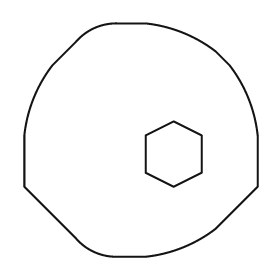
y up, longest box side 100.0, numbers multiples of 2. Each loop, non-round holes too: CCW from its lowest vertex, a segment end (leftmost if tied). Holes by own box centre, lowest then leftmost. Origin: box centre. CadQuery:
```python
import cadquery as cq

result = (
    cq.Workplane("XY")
    .moveTo(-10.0, -50.0)
    .lineTo(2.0, -50.0)
    .threePointArc((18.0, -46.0), (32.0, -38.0))
    .lineTo(50.0, -20.0)
    .lineTo(50.0, 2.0)
    .threePointArc((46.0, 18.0), (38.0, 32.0))
    .lineTo(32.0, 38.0)
    .threePointArc((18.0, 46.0), (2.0, 50.0))
    .lineTo(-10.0, 50.0)
    .threePointArc((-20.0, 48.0), (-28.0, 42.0))
    .lineTo(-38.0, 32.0)
    .threePointArc((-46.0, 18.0), (-50.0, 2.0))
    .lineTo(-50.0, -20.0)
    .lineTo(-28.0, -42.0)
    .threePointArc((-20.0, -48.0), (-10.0, -50.0))
    .close()
    .moveTo(14.0, -20.0)
    .lineTo(26.0, -14.0)
    .lineTo(26.0, 2.0)
    .lineTo(14.0, 8.0)
    .lineTo(2.0, 2.0)
    .lineTo(2.0, -14.0)
    .close()
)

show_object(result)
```